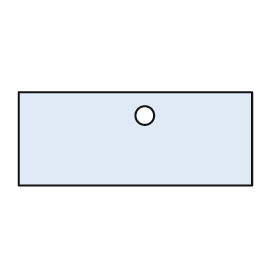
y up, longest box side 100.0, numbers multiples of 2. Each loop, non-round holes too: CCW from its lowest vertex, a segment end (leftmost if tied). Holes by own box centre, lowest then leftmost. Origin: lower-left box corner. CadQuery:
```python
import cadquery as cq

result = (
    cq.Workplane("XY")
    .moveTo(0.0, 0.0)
    .lineTo(100.0, 0.0)
    .lineTo(100.0, 40.0)
    .lineTo(0.0, 40.0)
    .close()
    .moveTo(54.0, 30.0)
    .circle(4.0)
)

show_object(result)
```